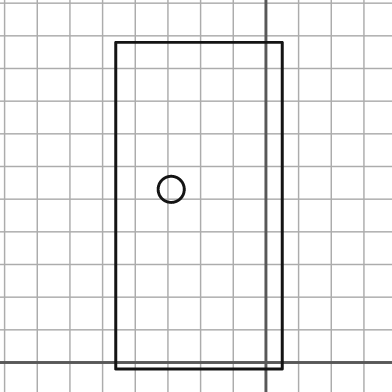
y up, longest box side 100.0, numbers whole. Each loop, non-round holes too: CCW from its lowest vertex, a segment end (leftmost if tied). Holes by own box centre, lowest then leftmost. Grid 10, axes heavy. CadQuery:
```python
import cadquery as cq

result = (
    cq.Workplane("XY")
    .moveTo(-46.0, -2.0)
    .lineTo(5.0, -2.0)
    .lineTo(5.0, 98.0)
    .lineTo(-46.0, 98.0)
    .close()
    .moveTo(-29.0, 53.0)
    .circle(4.0)
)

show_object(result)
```